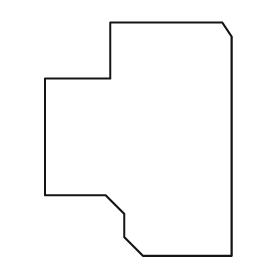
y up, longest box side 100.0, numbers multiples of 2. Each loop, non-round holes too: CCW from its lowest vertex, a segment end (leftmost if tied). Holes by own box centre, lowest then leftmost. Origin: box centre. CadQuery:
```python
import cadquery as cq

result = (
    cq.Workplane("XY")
    .moveTo(2.0, -50.0)
    .lineTo(40.0, -50.0)
    .lineTo(40.0, 44.0)
    .lineTo(36.0, 50.0)
    .lineTo(-12.0, 50.0)
    .lineTo(-12.0, 26.0)
    .lineTo(-40.0, 26.0)
    .lineTo(-40.0, -24.0)
    .lineTo(-14.0, -24.0)
    .lineTo(-6.0, -32.0)
    .lineTo(-6.0, -42.0)
    .close()
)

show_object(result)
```